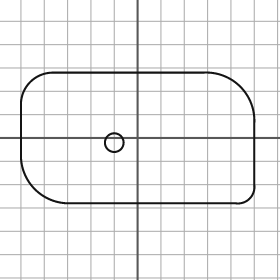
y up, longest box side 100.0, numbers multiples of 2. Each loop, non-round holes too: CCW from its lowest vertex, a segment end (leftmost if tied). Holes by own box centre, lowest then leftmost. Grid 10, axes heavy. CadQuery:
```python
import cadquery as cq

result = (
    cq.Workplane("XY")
    .moveTo(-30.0, -28.0)
    .lineTo(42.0, -28.0)
    .threePointArc((48.0, -26.0), (50.0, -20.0))
    .lineTo(50.0, 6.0)
    .threePointArc((44.0, 22.0), (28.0, 28.0))
    .lineTo(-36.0, 28.0)
    .threePointArc((-46.0, 24.0), (-50.0, 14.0))
    .lineTo(-50.0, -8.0)
    .threePointArc((-44.0, -22.0), (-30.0, -28.0))
    .close()
    .moveTo(-10.0, -2.0)
    .circle(4.0)
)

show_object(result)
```